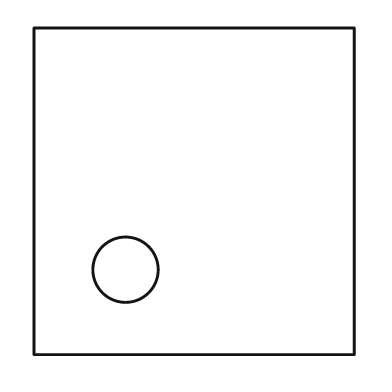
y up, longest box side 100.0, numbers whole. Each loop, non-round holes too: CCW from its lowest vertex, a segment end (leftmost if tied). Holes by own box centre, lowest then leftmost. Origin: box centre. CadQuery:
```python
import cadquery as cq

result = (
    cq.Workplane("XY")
    .moveTo(-49.0, -50.0)
    .lineTo(49.0, -50.0)
    .lineTo(49.0, 50.0)
    .lineTo(-49.0, 50.0)
    .close()
    .moveTo(-21.0, -24.0)
    .circle(10.0)
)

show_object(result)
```